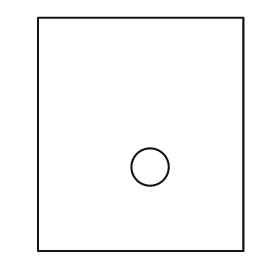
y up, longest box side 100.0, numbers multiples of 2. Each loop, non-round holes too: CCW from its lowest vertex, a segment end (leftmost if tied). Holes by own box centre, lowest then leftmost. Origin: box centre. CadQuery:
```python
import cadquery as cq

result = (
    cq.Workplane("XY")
    .moveTo(-44.0, -50.0)
    .lineTo(44.0, -50.0)
    .lineTo(44.0, 50.0)
    .lineTo(-44.0, 50.0)
    .close()
    .moveTo(4.0, -14.0)
    .circle(8.0)
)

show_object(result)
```